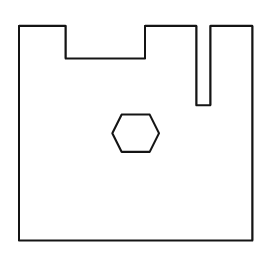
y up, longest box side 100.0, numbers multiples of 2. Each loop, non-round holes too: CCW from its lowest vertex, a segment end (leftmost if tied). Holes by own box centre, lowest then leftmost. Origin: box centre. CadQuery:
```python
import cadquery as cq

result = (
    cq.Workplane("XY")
    .moveTo(-50.0, -46.0)
    .lineTo(50.0, -46.0)
    .lineTo(50.0, 46.0)
    .lineTo(32.0, 46.0)
    .lineTo(32.0, 12.0)
    .lineTo(26.0, 12.0)
    .lineTo(26.0, 46.0)
    .lineTo(4.0, 46.0)
    .lineTo(4.0, 32.0)
    .lineTo(-30.0, 32.0)
    .lineTo(-30.0, 46.0)
    .lineTo(-50.0, 46.0)
    .close()
    .moveTo(-6.0, -8.0)
    .lineTo(6.0, -8.0)
    .lineTo(10.0, 0.0)
    .lineTo(6.0, 8.0)
    .lineTo(-6.0, 8.0)
    .lineTo(-10.0, 0.0)
    .close()
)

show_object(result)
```